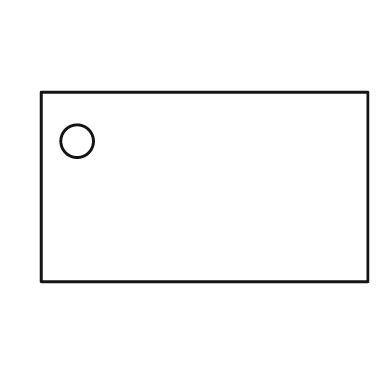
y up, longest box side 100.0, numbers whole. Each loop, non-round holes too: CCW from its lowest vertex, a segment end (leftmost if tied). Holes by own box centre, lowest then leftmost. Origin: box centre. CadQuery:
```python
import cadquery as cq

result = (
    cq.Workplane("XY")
    .moveTo(-50.0, -29.0)
    .lineTo(50.0, -29.0)
    .lineTo(50.0, 29.0)
    .lineTo(-50.0, 29.0)
    .close()
    .moveTo(-39.0, 14.0)
    .circle(5.0)
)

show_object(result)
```